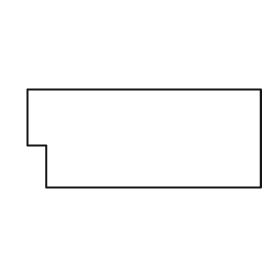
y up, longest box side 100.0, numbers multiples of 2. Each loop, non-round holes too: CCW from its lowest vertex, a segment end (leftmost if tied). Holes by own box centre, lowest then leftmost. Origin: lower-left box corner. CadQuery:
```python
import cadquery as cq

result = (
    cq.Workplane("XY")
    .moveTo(8.0, 0.0)
    .lineTo(100.0, 0.0)
    .lineTo(100.0, 42.0)
    .lineTo(0.0, 42.0)
    .lineTo(0.0, 18.0)
    .lineTo(8.0, 18.0)
    .close()
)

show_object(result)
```